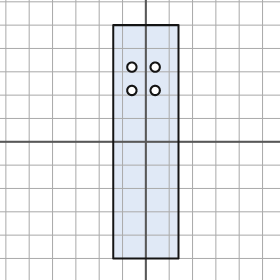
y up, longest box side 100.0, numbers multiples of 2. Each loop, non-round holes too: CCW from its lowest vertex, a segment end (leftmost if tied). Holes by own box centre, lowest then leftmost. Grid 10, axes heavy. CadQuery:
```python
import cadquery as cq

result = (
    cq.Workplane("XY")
    .moveTo(-14.0, -50.0)
    .lineTo(14.0, -50.0)
    .lineTo(14.0, 50.0)
    .lineTo(-14.0, 50.0)
    .close()
    .moveTo(-6.0, 22.0)
    .circle(2.0)
    .moveTo(4.0, 22.0)
    .circle(2.0)
    .moveTo(-6.0, 32.0)
    .circle(2.0)
    .moveTo(4.0, 32.0)
    .circle(2.0)
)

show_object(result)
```